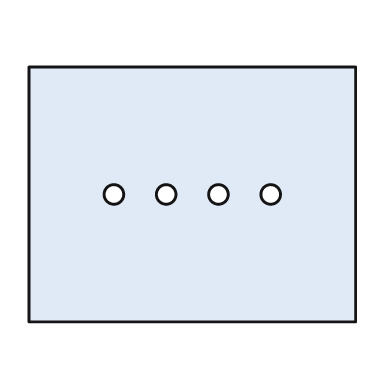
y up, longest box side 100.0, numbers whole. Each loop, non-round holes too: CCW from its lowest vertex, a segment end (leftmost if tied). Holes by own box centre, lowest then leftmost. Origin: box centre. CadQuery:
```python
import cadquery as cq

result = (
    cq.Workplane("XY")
    .moveTo(-50.0, -39.0)
    .lineTo(50.0, -39.0)
    .lineTo(50.0, 39.0)
    .lineTo(-50.0, 39.0)
    .close()
    .moveTo(-24.0, 0.0)
    .circle(3.0)
    .moveTo(-8.0, 0.0)
    .circle(3.0)
    .moveTo(8.0, 0.0)
    .circle(3.0)
    .moveTo(24.0, 0.0)
    .circle(3.0)
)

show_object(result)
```